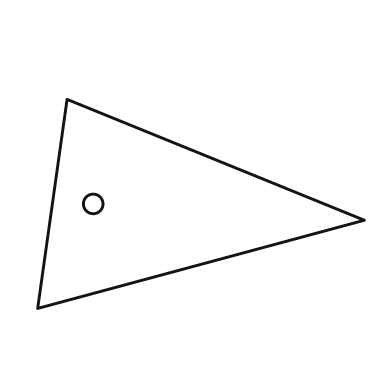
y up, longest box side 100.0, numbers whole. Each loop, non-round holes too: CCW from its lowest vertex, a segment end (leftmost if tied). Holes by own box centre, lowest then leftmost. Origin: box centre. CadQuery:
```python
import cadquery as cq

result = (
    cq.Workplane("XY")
    .moveTo(-50.0, -32.0)
    .lineTo(50.0, -5.0)
    .lineTo(-41.0, 32.0)
    .close()
    .moveTo(-33.0, 0.0)
    .circle(3.0)
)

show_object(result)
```